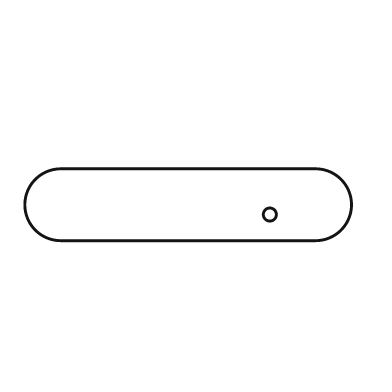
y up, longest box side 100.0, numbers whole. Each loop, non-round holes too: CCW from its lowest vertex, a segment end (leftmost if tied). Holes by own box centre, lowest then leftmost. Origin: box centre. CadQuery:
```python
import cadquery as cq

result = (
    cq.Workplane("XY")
    .moveTo(-39.0, -11.0)
    .lineTo(39.0, -11.0)
    .threePointArc((50.0, 0.0), (39.0, 11.0))
    .lineTo(-39.0, 11.0)
    .threePointArc((-50.0, 0.0), (-39.0, -11.0))
    .close()
    .moveTo(25.0, -3.0)
    .circle(2.0)
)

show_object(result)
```